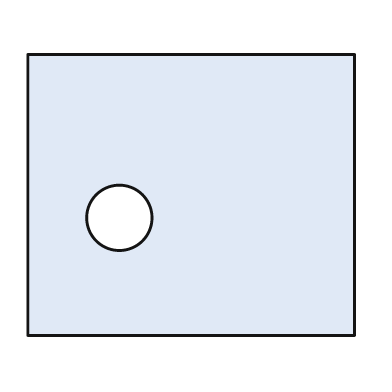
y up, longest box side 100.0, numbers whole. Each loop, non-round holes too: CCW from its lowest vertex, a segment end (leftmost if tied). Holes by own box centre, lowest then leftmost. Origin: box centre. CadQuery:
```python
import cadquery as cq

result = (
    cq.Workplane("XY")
    .moveTo(-50.0, -43.0)
    .lineTo(50.0, -43.0)
    .lineTo(50.0, 43.0)
    .lineTo(-50.0, 43.0)
    .close()
    .moveTo(-22.0, -7.0)
    .circle(10.0)
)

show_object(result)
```